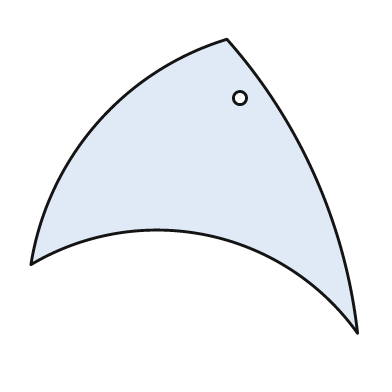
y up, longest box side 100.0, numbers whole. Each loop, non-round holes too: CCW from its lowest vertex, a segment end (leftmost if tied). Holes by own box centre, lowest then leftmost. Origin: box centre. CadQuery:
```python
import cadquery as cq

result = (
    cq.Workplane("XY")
    .moveTo(50.0, -45.0)
    .threePointArc((37.0, 3.0), (10.0, 45.0))
    .threePointArc((-30.0, 19.0), (-50.0, -24.0))
    .threePointArc((4.0, -15.0), (50.0, -45.0))
    .close()
    .moveTo(14.0, 27.0)
    .circle(2.0)
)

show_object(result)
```